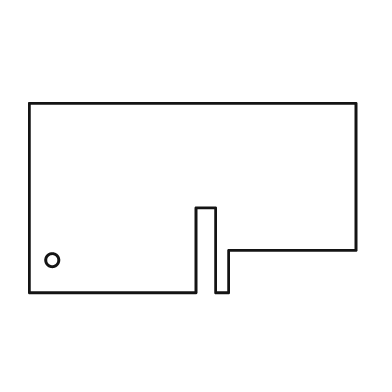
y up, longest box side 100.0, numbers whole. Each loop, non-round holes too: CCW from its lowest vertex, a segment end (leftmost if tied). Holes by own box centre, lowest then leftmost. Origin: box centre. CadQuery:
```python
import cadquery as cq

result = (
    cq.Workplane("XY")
    .moveTo(-50.0, -29.0)
    .lineTo(1.0, -29.0)
    .lineTo(1.0, -3.0)
    .lineTo(7.0, -3.0)
    .lineTo(7.0, -29.0)
    .lineTo(11.0, -29.0)
    .lineTo(11.0, -16.0)
    .lineTo(50.0, -16.0)
    .lineTo(50.0, 29.0)
    .lineTo(-50.0, 29.0)
    .close()
    .moveTo(-43.0, -19.0)
    .circle(2.0)
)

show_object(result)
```